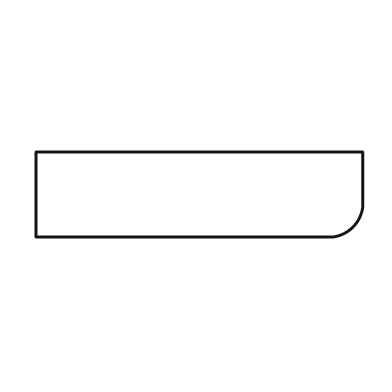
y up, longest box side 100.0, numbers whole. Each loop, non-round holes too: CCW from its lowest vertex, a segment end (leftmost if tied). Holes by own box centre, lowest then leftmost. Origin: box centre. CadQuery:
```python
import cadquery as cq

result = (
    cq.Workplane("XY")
    .moveTo(-50.0, -13.0)
    .lineTo(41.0, -13.0)
    .threePointArc((47.0, -10.0), (50.0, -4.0))
    .lineTo(50.0, 13.0)
    .lineTo(-50.0, 13.0)
    .close()
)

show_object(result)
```